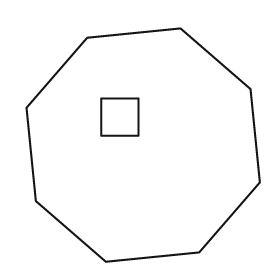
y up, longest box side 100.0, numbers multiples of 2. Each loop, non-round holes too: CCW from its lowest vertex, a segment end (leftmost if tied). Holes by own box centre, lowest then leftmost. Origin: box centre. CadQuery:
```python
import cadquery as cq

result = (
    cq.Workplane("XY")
    .moveTo(-16.0, -50.0)
    .lineTo(24.0, -46.0)
    .lineTo(50.0, -16.0)
    .lineTo(46.0, 24.0)
    .lineTo(16.0, 50.0)
    .lineTo(-24.0, 46.0)
    .lineTo(-50.0, 16.0)
    .lineTo(-46.0, -24.0)
    .close()
    .moveTo(-18.0, 4.0)
    .lineTo(-2.0, 4.0)
    .lineTo(-2.0, 20.0)
    .lineTo(-18.0, 20.0)
    .close()
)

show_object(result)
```